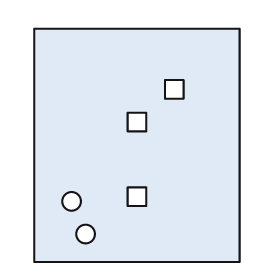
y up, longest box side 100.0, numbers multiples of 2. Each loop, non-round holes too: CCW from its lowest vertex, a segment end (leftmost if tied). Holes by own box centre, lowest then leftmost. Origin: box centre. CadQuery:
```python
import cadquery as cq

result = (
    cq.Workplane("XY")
    .moveTo(-44.0, -50.0)
    .lineTo(44.0, -50.0)
    .lineTo(44.0, 50.0)
    .lineTo(-44.0, 50.0)
    .close()
    .moveTo(-22.0, -38.0)
    .circle(4.0)
    .moveTo(-28.0, -24.0)
    .circle(4.0)
    .moveTo(-4.0, -26.0)
    .lineTo(4.0, -26.0)
    .lineTo(4.0, -18.0)
    .lineTo(-4.0, -18.0)
    .close()
    .moveTo(-4.0, 6.0)
    .lineTo(4.0, 6.0)
    .lineTo(4.0, 14.0)
    .lineTo(-4.0, 14.0)
    .close()
    .moveTo(12.0, 20.0)
    .lineTo(20.0, 20.0)
    .lineTo(20.0, 28.0)
    .lineTo(12.0, 28.0)
    .close()
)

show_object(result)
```